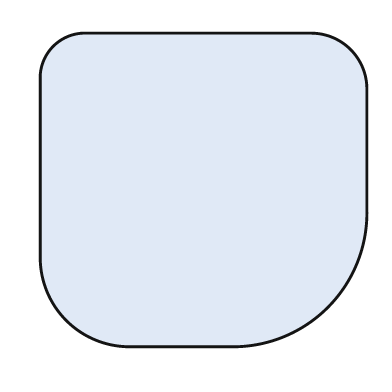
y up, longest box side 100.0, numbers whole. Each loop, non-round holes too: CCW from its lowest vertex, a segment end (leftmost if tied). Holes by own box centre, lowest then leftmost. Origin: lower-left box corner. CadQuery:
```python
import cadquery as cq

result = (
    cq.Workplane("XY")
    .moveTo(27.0, 0.0)
    .lineTo(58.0, 0.0)
    .threePointArc((88.0, 12.0), (100.0, 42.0))
    .lineTo(100.0, 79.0)
    .threePointArc((95.0, 91.0), (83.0, 96.0))
    .lineTo(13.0, 96.0)
    .threePointArc((4.0, 92.0), (0.0, 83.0))
    .lineTo(0.0, 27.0)
    .threePointArc((8.0, 8.0), (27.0, 0.0))
    .close()
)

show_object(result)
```